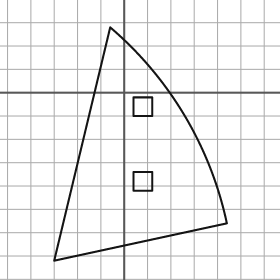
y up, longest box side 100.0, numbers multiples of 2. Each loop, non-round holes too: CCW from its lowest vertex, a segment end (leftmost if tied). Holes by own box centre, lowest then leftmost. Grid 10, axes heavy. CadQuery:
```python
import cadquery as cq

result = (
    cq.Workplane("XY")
    .moveTo(-30.0, -72.0)
    .lineTo(44.0, -56.0)
    .threePointArc((26.0, -10.0), (-6.0, 28.0))
    .close()
    .moveTo(4.0, -42.0)
    .lineTo(12.0, -42.0)
    .lineTo(12.0, -34.0)
    .lineTo(4.0, -34.0)
    .close()
    .moveTo(4.0, -10.0)
    .lineTo(12.0, -10.0)
    .lineTo(12.0, -2.0)
    .lineTo(4.0, -2.0)
    .close()
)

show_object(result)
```